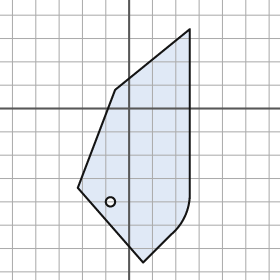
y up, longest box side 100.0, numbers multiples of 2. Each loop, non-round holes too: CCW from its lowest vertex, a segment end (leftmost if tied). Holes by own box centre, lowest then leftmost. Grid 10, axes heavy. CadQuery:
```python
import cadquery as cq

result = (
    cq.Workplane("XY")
    .moveTo(6.0, -66.0)
    .lineTo(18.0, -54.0)
    .threePointArc((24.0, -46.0), (26.0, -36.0))
    .lineTo(26.0, 34.0)
    .lineTo(-6.0, 8.0)
    .lineTo(-22.0, -34.0)
    .close()
    .moveTo(-8.0, -40.0)
    .circle(2.0)
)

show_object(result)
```